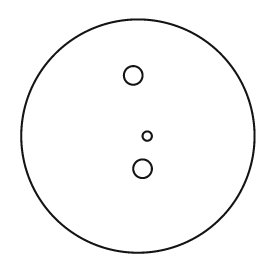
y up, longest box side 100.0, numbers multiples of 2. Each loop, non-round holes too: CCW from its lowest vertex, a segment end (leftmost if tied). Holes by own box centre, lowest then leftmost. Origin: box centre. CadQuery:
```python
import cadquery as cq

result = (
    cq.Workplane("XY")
    .moveTo(0.0, 0.0)
    .circle(50.0)
    .moveTo(2.0, -14.0)
    .circle(4.0)
    .moveTo(4.0, 0.0)
    .circle(2.0)
    .moveTo(-2.0, 26.0)
    .circle(4.0)
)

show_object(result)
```